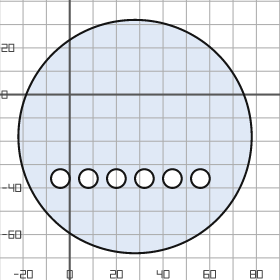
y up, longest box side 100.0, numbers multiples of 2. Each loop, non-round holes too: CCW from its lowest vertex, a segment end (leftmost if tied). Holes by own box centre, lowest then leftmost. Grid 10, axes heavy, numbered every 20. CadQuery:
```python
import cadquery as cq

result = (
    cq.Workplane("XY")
    .moveTo(28.0, -18.0)
    .circle(50.0)
    .moveTo(-4.0, -36.0)
    .circle(4.0)
    .moveTo(8.0, -36.0)
    .circle(4.0)
    .moveTo(20.0, -36.0)
    .circle(4.0)
    .moveTo(32.0, -36.0)
    .circle(4.0)
    .moveTo(44.0, -36.0)
    .circle(4.0)
    .moveTo(56.0, -36.0)
    .circle(4.0)
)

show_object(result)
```